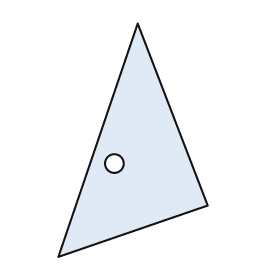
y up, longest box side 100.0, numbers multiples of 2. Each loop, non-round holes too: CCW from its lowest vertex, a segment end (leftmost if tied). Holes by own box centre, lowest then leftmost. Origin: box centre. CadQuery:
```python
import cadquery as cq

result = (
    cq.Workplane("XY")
    .moveTo(-32.0, -50.0)
    .lineTo(32.0, -28.0)
    .lineTo(2.0, 50.0)
    .close()
    .moveTo(-8.0, -10.0)
    .circle(4.0)
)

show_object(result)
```